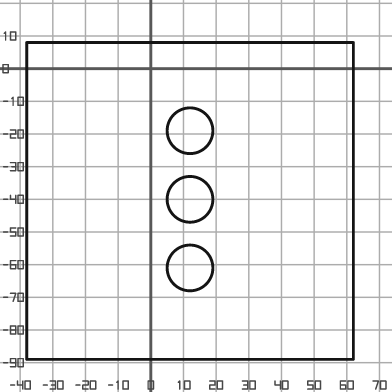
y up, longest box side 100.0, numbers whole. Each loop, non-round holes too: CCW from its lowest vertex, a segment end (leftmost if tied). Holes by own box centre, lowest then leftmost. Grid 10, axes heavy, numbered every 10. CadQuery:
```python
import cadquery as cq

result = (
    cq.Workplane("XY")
    .moveTo(-38.0, -89.0)
    .lineTo(62.0, -89.0)
    .lineTo(62.0, 8.0)
    .lineTo(-38.0, 8.0)
    .close()
    .moveTo(12.0, -61.0)
    .circle(7.0)
    .moveTo(12.0, -40.0)
    .circle(7.0)
    .moveTo(12.0, -19.0)
    .circle(7.0)
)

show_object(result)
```